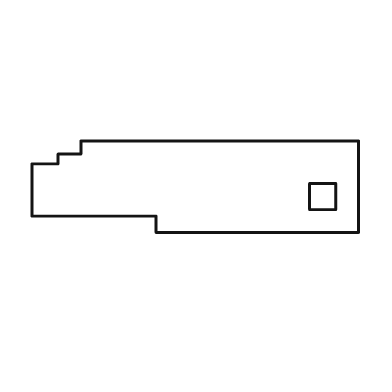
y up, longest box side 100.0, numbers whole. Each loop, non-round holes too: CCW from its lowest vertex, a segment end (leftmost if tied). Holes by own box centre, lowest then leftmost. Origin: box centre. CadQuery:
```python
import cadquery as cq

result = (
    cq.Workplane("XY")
    .moveTo(-12.0, -14.0)
    .lineTo(50.0, -14.0)
    .lineTo(50.0, 14.0)
    .lineTo(-35.0, 14.0)
    .lineTo(-35.0, 10.0)
    .lineTo(-42.0, 10.0)
    .lineTo(-42.0, 7.0)
    .lineTo(-50.0, 7.0)
    .lineTo(-50.0, -9.0)
    .lineTo(-12.0, -9.0)
    .close()
    .moveTo(35.0, -7.0)
    .lineTo(43.0, -7.0)
    .lineTo(43.0, 1.0)
    .lineTo(35.0, 1.0)
    .close()
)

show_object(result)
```